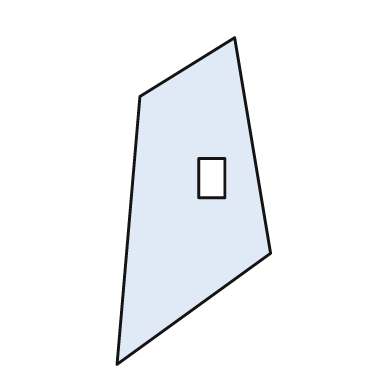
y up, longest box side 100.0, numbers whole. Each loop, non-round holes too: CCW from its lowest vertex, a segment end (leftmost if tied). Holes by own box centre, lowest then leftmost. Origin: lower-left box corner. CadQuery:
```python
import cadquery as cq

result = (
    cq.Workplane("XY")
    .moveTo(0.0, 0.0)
    .lineTo(47.0, 34.0)
    .lineTo(36.0, 100.0)
    .lineTo(7.0, 82.0)
    .close()
    .moveTo(25.0, 51.0)
    .lineTo(33.0, 51.0)
    .lineTo(33.0, 63.0)
    .lineTo(25.0, 63.0)
    .close()
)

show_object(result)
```